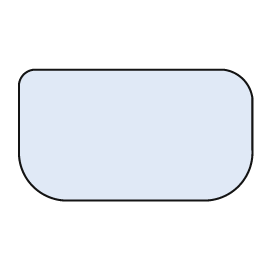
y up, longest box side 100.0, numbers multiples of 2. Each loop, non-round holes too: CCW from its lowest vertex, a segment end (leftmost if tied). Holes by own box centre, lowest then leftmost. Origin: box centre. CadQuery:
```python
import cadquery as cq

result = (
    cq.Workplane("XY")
    .moveTo(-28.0, -28.0)
    .lineTo(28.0, -28.0)
    .threePointArc((44.0, -22.0), (50.0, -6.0))
    .lineTo(50.0, 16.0)
    .threePointArc((46.0, 24.0), (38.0, 28.0))
    .lineTo(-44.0, 28.0)
    .threePointArc((-48.0, 26.0), (-50.0, 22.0))
    .lineTo(-50.0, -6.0)
    .threePointArc((-44.0, -22.0), (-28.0, -28.0))
    .close()
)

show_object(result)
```